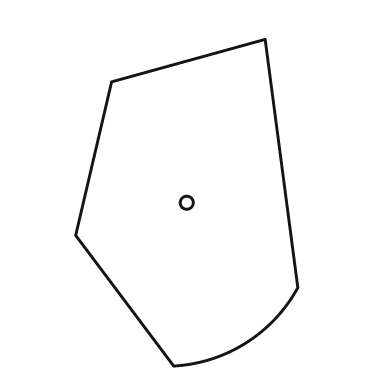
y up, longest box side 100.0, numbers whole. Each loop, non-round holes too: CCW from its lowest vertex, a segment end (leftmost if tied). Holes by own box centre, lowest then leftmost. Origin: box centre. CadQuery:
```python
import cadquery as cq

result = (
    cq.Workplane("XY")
    .moveTo(-4.0, -50.0)
    .threePointArc((18.0, -43.0), (34.0, -26.0))
    .lineTo(24.0, 50.0)
    .lineTo(-23.0, 37.0)
    .lineTo(-34.0, -10.0)
    .close()
    .moveTo(0.0, 0.0)
    .circle(2.0)
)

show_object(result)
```